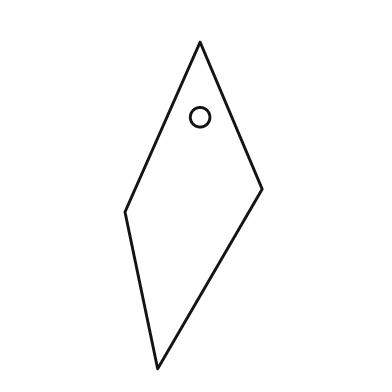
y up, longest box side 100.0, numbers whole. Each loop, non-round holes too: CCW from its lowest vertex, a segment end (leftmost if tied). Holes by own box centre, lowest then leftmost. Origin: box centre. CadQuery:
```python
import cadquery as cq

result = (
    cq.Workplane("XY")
    .moveTo(-11.0, -50.0)
    .lineTo(21.0, 5.0)
    .lineTo(2.0, 50.0)
    .lineTo(-21.0, -2.0)
    .close()
    .moveTo(2.0, 27.0)
    .circle(3.0)
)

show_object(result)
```